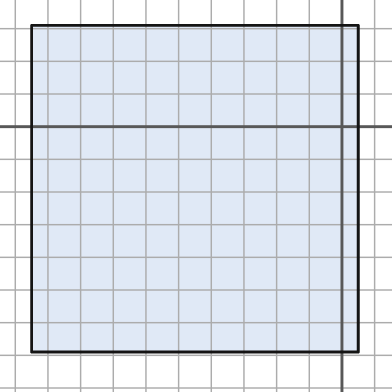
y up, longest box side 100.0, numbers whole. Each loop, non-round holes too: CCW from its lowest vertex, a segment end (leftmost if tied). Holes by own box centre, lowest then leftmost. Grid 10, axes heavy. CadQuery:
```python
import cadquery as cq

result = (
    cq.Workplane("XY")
    .moveTo(-95.0, -69.0)
    .lineTo(5.0, -69.0)
    .lineTo(5.0, 31.0)
    .lineTo(-95.0, 31.0)
    .close()
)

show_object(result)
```